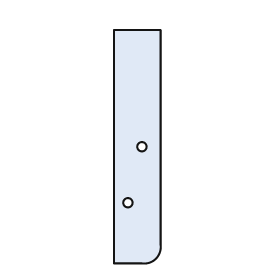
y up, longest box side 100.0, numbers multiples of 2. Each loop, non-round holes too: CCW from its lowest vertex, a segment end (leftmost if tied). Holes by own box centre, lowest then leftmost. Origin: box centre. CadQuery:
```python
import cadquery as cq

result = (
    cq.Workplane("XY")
    .moveTo(-10.0, -50.0)
    .lineTo(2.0, -50.0)
    .threePointArc((8.0, -48.0), (10.0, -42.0))
    .lineTo(10.0, 50.0)
    .lineTo(-10.0, 50.0)
    .close()
    .moveTo(-4.0, -24.0)
    .circle(2.0)
    .moveTo(2.0, 0.0)
    .circle(2.0)
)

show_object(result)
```